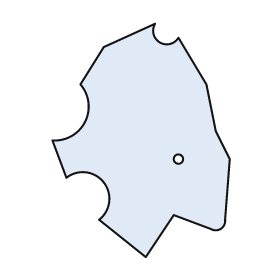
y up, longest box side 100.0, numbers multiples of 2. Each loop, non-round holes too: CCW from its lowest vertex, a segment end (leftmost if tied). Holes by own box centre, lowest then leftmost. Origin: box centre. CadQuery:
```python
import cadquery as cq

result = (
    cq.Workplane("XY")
    .moveTo(2.0, -50.0)
    .lineTo(14.0, -32.0)
    .lineTo(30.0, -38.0)
    .threePointArc((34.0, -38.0), (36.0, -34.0))
    .lineTo(38.0, -8.0)
    .lineTo(32.0, 4.0)
    .lineTo(28.0, 24.0)
    .lineTo(16.0, 44.0)
    .threePointArc((8.0, 42.0), (6.0, 50.0))
    .lineTo(-16.0, 40.0)
    .lineTo(-26.0, 24.0)
    .threePointArc((-24.0, 8.0), (-38.0, 0.0))
    .lineTo(-32.0, -16.0)
    .threePointArc((-16.0, -18.0), (-18.0, -34.0))
    .close()
    .moveTo(16.0, -8.0)
    .circle(2.0)
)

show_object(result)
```